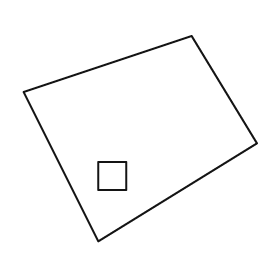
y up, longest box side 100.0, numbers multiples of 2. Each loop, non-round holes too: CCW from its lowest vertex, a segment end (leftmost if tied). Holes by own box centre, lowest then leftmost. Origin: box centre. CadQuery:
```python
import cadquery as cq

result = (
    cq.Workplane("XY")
    .moveTo(-18.0, -44.0)
    .lineTo(50.0, -2.0)
    .lineTo(22.0, 44.0)
    .lineTo(-50.0, 20.0)
    .close()
    .moveTo(-18.0, -22.0)
    .lineTo(-6.0, -22.0)
    .lineTo(-6.0, -10.0)
    .lineTo(-18.0, -10.0)
    .close()
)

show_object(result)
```